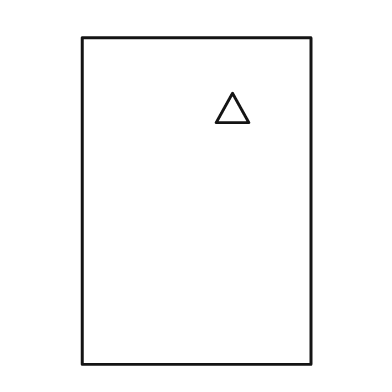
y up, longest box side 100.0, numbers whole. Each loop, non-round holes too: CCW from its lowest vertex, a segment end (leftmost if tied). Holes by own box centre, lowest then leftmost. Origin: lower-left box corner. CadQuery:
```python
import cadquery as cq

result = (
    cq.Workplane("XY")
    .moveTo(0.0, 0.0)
    .lineTo(70.0, 0.0)
    .lineTo(70.0, 100.0)
    .lineTo(0.0, 100.0)
    .close()
    .moveTo(41.0, 74.0)
    .lineTo(51.0, 74.0)
    .lineTo(46.0, 83.0)
    .close()
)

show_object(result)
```